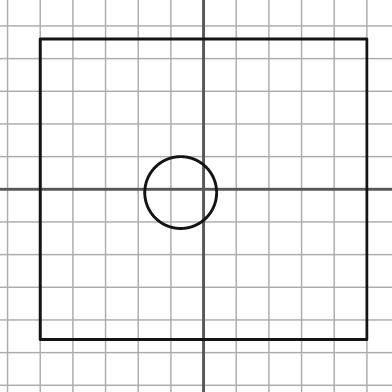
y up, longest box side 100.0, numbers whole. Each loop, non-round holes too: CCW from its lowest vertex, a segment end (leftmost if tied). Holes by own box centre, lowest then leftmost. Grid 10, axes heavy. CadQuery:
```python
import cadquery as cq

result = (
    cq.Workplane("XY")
    .moveTo(-50.0, -46.0)
    .lineTo(50.0, -46.0)
    .lineTo(50.0, 46.0)
    .lineTo(-50.0, 46.0)
    .close()
    .moveTo(-7.0, -1.0)
    .circle(11.0)
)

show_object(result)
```